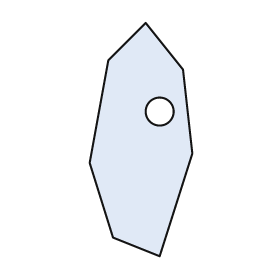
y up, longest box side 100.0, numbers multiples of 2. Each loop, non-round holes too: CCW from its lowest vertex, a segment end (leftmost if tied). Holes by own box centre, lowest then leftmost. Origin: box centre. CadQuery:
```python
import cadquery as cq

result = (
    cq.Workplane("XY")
    .moveTo(8.0, -50.0)
    .lineTo(22.0, -6.0)
    .lineTo(18.0, 30.0)
    .lineTo(2.0, 50.0)
    .lineTo(-14.0, 34.0)
    .lineTo(-22.0, -10.0)
    .lineTo(-12.0, -42.0)
    .close()
    .moveTo(8.0, 12.0)
    .circle(6.0)
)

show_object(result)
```